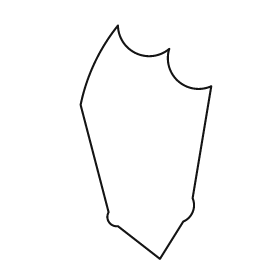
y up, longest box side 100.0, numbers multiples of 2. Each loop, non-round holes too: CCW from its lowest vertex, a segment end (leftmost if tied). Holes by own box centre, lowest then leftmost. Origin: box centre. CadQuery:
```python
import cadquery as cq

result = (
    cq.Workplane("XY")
    .moveTo(6.0, -50.0)
    .lineTo(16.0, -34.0)
    .threePointArc((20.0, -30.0), (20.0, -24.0))
    .lineTo(28.0, 24.0)
    .threePointArc((14.0, 26.0), (10.0, 40.0))
    .threePointArc((-4.0, 38.0), (-12.0, 50.0))
    .threePointArc((-22.0, 34.0), (-28.0, 16.0))
    .lineTo(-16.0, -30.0)
    .threePointArc((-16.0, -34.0), (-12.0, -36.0))
    .close()
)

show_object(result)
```